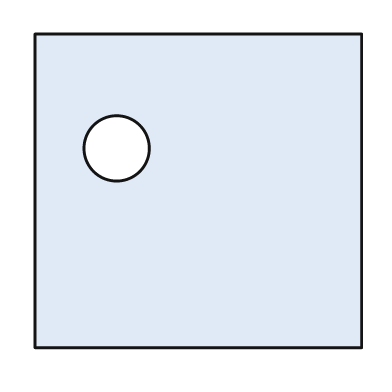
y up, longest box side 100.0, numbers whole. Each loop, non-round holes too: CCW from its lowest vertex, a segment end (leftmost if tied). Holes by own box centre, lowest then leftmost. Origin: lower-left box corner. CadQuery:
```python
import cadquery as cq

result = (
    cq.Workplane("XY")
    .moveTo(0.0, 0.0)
    .lineTo(100.0, 0.0)
    .lineTo(100.0, 96.0)
    .lineTo(0.0, 96.0)
    .close()
    .moveTo(25.0, 61.0)
    .circle(10.0)
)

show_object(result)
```